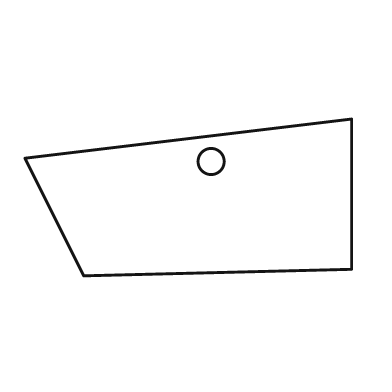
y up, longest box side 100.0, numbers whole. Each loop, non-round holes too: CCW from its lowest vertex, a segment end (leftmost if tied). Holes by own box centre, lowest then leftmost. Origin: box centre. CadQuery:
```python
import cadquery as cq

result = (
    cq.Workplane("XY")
    .moveTo(-32.0, -24.0)
    .lineTo(50.0, -22.0)
    .lineTo(50.0, 24.0)
    .lineTo(-50.0, 12.0)
    .close()
    .moveTo(7.0, 11.0)
    .circle(4.0)
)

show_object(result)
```